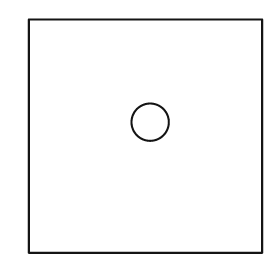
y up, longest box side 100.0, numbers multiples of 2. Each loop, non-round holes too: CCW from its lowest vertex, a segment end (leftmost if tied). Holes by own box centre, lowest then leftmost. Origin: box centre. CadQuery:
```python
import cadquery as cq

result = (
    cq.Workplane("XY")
    .moveTo(-50.0, -50.0)
    .lineTo(50.0, -50.0)
    .lineTo(50.0, 50.0)
    .lineTo(-50.0, 50.0)
    .close()
    .moveTo(2.0, 6.0)
    .circle(8.0)
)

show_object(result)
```